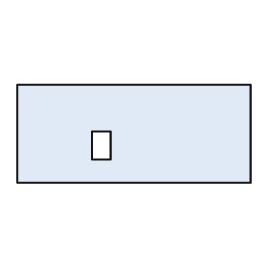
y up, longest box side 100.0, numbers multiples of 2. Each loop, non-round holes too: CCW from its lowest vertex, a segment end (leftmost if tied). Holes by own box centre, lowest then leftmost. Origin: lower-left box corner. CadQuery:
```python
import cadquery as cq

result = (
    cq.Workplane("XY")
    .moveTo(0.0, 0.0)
    .lineTo(100.0, 0.0)
    .lineTo(100.0, 42.0)
    .lineTo(0.0, 42.0)
    .close()
    .moveTo(32.0, 10.0)
    .lineTo(40.0, 10.0)
    .lineTo(40.0, 22.0)
    .lineTo(32.0, 22.0)
    .close()
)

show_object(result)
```